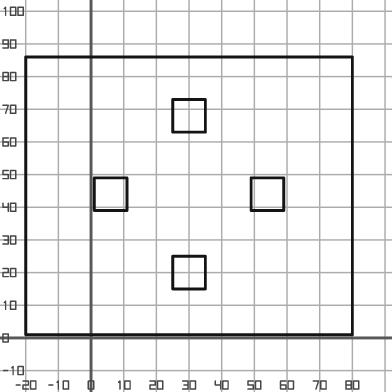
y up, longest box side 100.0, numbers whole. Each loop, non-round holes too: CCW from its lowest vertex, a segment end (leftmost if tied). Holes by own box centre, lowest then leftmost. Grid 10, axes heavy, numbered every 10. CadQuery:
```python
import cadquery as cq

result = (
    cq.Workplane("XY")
    .moveTo(-20.0, 1.0)
    .lineTo(80.0, 1.0)
    .lineTo(80.0, 86.0)
    .lineTo(-20.0, 86.0)
    .close()
    .moveTo(25.0, 15.0)
    .lineTo(35.0, 15.0)
    .lineTo(35.0, 25.0)
    .lineTo(25.0, 25.0)
    .close()
    .moveTo(1.0, 39.0)
    .lineTo(11.0, 39.0)
    .lineTo(11.0, 49.0)
    .lineTo(1.0, 49.0)
    .close()
    .moveTo(49.0, 39.0)
    .lineTo(59.0, 39.0)
    .lineTo(59.0, 49.0)
    .lineTo(49.0, 49.0)
    .close()
    .moveTo(25.0, 63.0)
    .lineTo(35.0, 63.0)
    .lineTo(35.0, 73.0)
    .lineTo(25.0, 73.0)
    .close()
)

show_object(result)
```